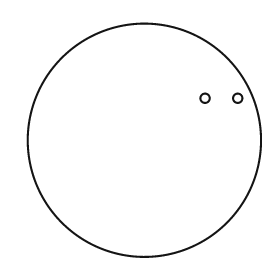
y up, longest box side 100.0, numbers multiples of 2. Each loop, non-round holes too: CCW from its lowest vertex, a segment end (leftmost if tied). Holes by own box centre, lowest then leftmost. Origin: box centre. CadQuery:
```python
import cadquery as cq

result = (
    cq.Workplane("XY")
    .moveTo(0.0, 0.0)
    .circle(50.0)
    .moveTo(26.0, 18.0)
    .circle(2.0)
    .moveTo(40.0, 18.0)
    .circle(2.0)
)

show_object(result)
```